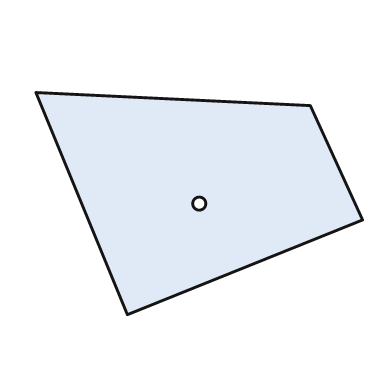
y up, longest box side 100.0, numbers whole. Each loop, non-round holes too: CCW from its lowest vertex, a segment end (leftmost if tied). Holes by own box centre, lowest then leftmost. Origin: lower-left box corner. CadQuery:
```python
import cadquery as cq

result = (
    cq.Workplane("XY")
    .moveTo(28.0, 0.0)
    .lineTo(100.0, 29.0)
    .lineTo(84.0, 64.0)
    .lineTo(0.0, 68.0)
    .close()
    .moveTo(50.0, 34.0)
    .circle(2.0)
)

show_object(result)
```